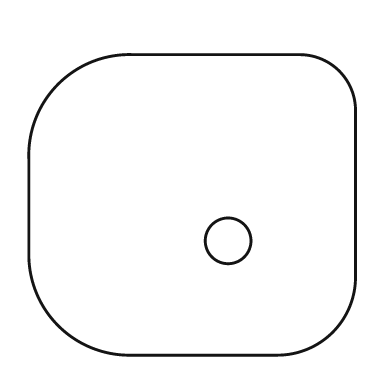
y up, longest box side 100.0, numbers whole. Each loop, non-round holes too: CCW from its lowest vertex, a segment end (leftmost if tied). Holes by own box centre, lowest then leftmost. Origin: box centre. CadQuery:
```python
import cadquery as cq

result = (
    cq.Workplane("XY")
    .moveTo(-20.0, -46.0)
    .lineTo(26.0, -46.0)
    .threePointArc((43.0, -39.0), (50.0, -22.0))
    .lineTo(50.0, 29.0)
    .threePointArc((45.0, 41.0), (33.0, 46.0))
    .lineTo(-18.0, 46.0)
    .threePointArc((-41.0, 37.0), (-50.0, 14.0))
    .lineTo(-50.0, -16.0)
    .threePointArc((-41.0, -37.0), (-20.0, -46.0))
    .close()
    .moveTo(11.0, -11.0)
    .circle(7.0)
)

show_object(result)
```